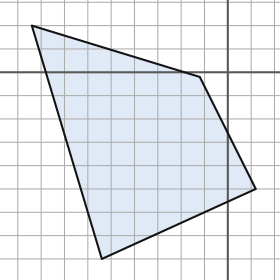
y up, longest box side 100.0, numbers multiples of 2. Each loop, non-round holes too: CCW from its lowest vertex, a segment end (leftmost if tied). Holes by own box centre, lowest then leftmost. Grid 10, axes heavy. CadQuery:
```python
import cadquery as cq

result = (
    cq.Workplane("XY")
    .moveTo(-54.0, -80.0)
    .lineTo(12.0, -50.0)
    .lineTo(-12.0, -2.0)
    .lineTo(-84.0, 20.0)
    .close()
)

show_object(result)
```